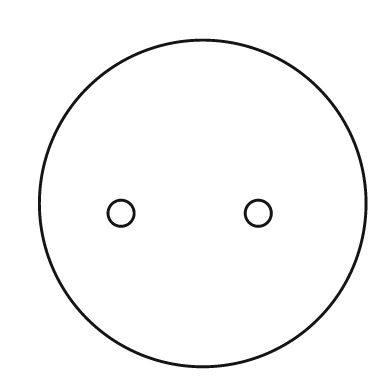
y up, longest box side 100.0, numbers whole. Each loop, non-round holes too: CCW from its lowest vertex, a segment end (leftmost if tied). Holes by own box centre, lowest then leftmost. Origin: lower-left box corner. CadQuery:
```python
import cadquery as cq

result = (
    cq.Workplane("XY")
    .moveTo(50.0, 50.0)
    .circle(50.0)
    .moveTo(25.0, 47.0)
    .circle(4.0)
    .moveTo(67.0, 47.0)
    .circle(4.0)
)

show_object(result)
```